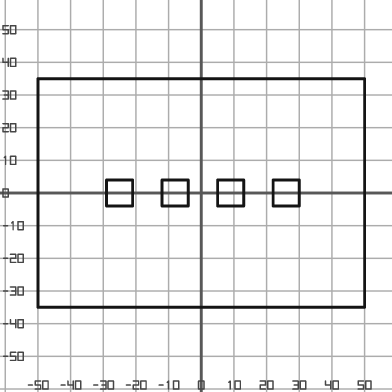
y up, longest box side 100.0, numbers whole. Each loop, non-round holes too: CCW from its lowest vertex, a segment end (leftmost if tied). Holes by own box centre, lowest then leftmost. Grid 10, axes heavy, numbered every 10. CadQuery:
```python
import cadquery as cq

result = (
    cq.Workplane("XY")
    .moveTo(-50.0, -35.0)
    .lineTo(50.0, -35.0)
    .lineTo(50.0, 35.0)
    .lineTo(-50.0, 35.0)
    .close()
    .moveTo(-29.0, -4.0)
    .lineTo(-21.0, -4.0)
    .lineTo(-21.0, 4.0)
    .lineTo(-29.0, 4.0)
    .close()
    .moveTo(-12.0, -4.0)
    .lineTo(-4.0, -4.0)
    .lineTo(-4.0, 4.0)
    .lineTo(-12.0, 4.0)
    .close()
    .moveTo(5.0, -4.0)
    .lineTo(13.0, -4.0)
    .lineTo(13.0, 4.0)
    .lineTo(5.0, 4.0)
    .close()
    .moveTo(22.0, -4.0)
    .lineTo(30.0, -4.0)
    .lineTo(30.0, 4.0)
    .lineTo(22.0, 4.0)
    .close()
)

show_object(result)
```